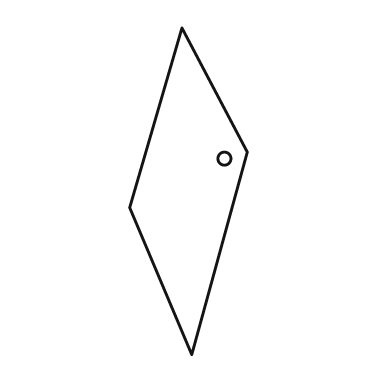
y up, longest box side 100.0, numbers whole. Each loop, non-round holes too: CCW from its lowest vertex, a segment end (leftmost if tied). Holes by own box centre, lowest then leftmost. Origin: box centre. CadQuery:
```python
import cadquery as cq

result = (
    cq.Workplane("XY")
    .moveTo(1.0, -50.0)
    .lineTo(18.0, 12.0)
    .lineTo(-2.0, 50.0)
    .lineTo(-18.0, -5.0)
    .close()
    .moveTo(11.0, 10.0)
    .circle(2.0)
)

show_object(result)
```